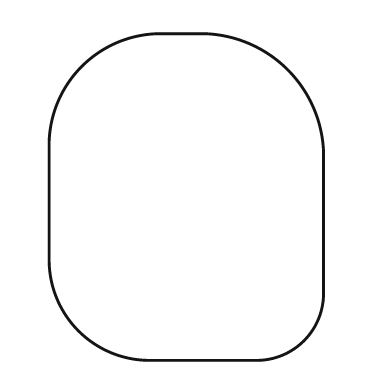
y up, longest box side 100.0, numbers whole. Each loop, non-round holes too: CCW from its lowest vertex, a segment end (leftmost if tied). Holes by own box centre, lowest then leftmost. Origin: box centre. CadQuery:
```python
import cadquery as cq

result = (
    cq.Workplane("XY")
    .moveTo(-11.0, -50.0)
    .lineTo(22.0, -50.0)
    .threePointArc((36.0, -44.0), (42.0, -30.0))
    .lineTo(42.0, 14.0)
    .threePointArc((31.0, 39.0), (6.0, 50.0))
    .lineTo(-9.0, 50.0)
    .threePointArc((-32.0, 40.0), (-42.0, 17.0))
    .lineTo(-42.0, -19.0)
    .threePointArc((-33.0, -41.0), (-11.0, -50.0))
    .close()
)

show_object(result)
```